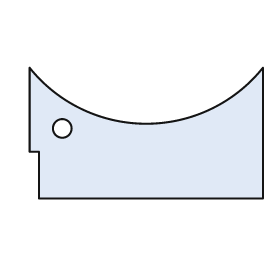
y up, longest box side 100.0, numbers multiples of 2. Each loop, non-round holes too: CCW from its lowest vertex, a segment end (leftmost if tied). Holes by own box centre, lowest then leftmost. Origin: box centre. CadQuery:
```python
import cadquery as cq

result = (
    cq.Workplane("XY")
    .moveTo(-46.0, -28.0)
    .lineTo(50.0, -28.0)
    .lineTo(50.0, 28.0)
    .threePointArc((0.0, 4.0), (-50.0, 28.0))
    .lineTo(-50.0, -8.0)
    .lineTo(-46.0, -8.0)
    .close()
    .moveTo(-36.0, 2.0)
    .circle(4.0)
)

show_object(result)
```